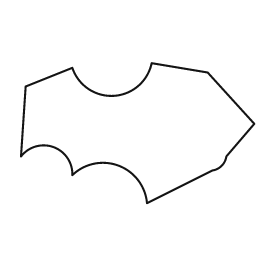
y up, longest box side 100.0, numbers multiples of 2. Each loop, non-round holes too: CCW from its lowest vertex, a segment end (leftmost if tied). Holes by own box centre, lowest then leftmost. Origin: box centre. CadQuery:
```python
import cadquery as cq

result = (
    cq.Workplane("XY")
    .moveTo(4.0, -30.0)
    .lineTo(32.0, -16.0)
    .threePointArc((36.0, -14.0), (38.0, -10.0))
    .lineTo(50.0, 4.0)
    .lineTo(30.0, 26.0)
    .lineTo(6.0, 30.0)
    .threePointArc((-10.0, 16.0), (-28.0, 28.0))
    .lineTo(-48.0, 20.0)
    .lineTo(-50.0, -10.0)
    .threePointArc((-36.0, -6.0), (-28.0, -18.0))
    .threePointArc((-8.0, -14.0), (4.0, -30.0))
    .close()
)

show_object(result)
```